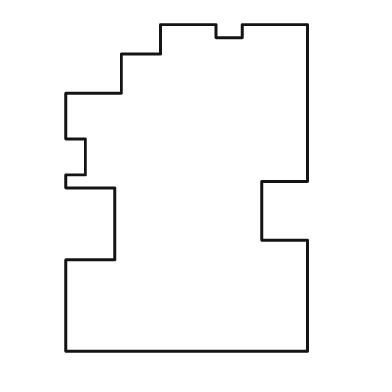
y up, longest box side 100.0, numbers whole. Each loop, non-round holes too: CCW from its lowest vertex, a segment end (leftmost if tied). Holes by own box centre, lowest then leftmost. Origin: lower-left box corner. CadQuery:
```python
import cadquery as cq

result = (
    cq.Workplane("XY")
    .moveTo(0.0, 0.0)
    .lineTo(74.0, 0.0)
    .lineTo(74.0, 34.0)
    .lineTo(60.0, 34.0)
    .lineTo(60.0, 52.0)
    .lineTo(74.0, 52.0)
    .lineTo(74.0, 100.0)
    .lineTo(54.0, 100.0)
    .lineTo(54.0, 96.0)
    .lineTo(46.0, 96.0)
    .lineTo(46.0, 100.0)
    .lineTo(29.0, 100.0)
    .lineTo(29.0, 91.0)
    .lineTo(17.0, 91.0)
    .lineTo(17.0, 79.0)
    .lineTo(0.0, 79.0)
    .lineTo(0.0, 65.0)
    .lineTo(6.0, 65.0)
    .lineTo(6.0, 54.0)
    .lineTo(0.0, 54.0)
    .lineTo(0.0, 50.0)
    .lineTo(15.0, 50.0)
    .lineTo(15.0, 28.0)
    .lineTo(0.0, 28.0)
    .close()
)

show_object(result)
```